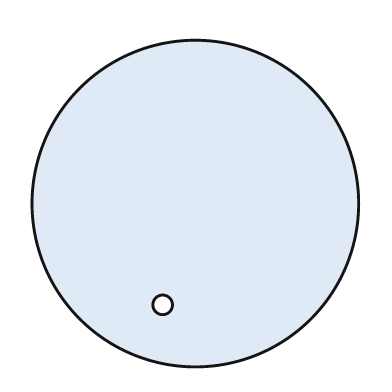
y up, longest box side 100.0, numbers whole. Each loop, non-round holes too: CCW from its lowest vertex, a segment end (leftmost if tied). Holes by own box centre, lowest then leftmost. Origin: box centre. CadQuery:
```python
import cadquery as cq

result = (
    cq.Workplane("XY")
    .moveTo(0.0, 0.0)
    .circle(50.0)
    .moveTo(-10.0, -31.0)
    .circle(3.0)
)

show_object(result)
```